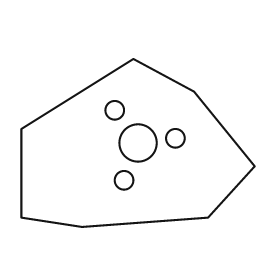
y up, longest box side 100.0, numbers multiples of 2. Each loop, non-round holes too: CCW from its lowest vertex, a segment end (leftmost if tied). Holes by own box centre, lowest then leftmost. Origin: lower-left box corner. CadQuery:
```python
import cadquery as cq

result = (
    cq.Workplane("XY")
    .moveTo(26.0, 0.0)
    .lineTo(80.0, 4.0)
    .lineTo(100.0, 26.0)
    .lineTo(74.0, 58.0)
    .lineTo(48.0, 72.0)
    .lineTo(0.0, 42.0)
    .lineTo(0.0, 4.0)
    .close()
    .moveTo(44.0, 20.0)
    .circle(4.0)
    .moveTo(50.0, 36.0)
    .circle(8.0)
    .moveTo(66.0, 38.0)
    .circle(4.0)
    .moveTo(40.0, 50.0)
    .circle(4.0)
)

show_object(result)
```